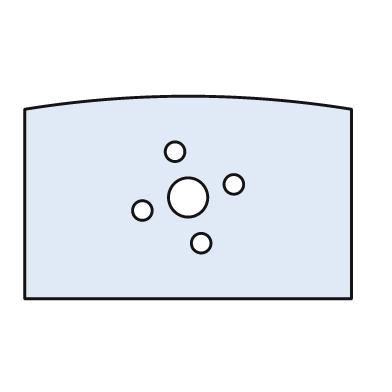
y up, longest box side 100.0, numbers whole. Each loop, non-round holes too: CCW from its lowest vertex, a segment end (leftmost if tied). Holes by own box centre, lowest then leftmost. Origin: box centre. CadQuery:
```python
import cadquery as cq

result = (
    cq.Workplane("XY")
    .moveTo(-50.0, -31.0)
    .lineTo(50.0, -31.0)
    .lineTo(50.0, 27.0)
    .threePointArc((0.0, 31.0), (-50.0, 27.0))
    .close()
    .moveTo(4.0, -14.0)
    .circle(3.0)
    .moveTo(-14.0, -4.0)
    .circle(3.0)
    .moveTo(0.0, 0.0)
    .circle(6.0)
    .moveTo(14.0, 4.0)
    .circle(3.0)
    .moveTo(-4.0, 14.0)
    .circle(3.0)
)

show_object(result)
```